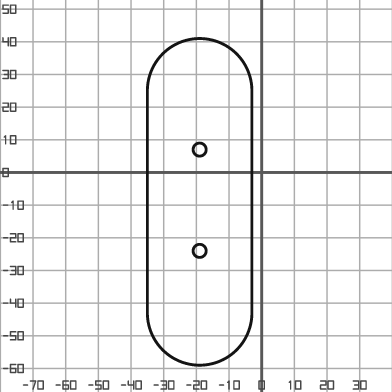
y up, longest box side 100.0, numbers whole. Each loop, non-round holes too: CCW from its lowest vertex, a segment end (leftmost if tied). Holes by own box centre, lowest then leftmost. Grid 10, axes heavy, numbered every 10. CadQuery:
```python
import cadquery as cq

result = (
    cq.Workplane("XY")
    .moveTo(-35.0, -43.0)
    .threePointArc((-19.0, -59.0), (-3.0, -43.0))
    .lineTo(-3.0, 25.0)
    .threePointArc((-19.0, 41.0), (-35.0, 25.0))
    .close()
    .moveTo(-19.0, -24.0)
    .circle(2.0)
    .moveTo(-19.0, 7.0)
    .circle(2.0)
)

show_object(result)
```